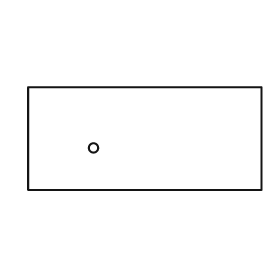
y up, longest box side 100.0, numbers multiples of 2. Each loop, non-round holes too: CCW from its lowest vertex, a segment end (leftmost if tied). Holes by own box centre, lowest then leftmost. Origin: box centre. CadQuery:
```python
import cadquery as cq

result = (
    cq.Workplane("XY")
    .moveTo(-50.0, -22.0)
    .lineTo(50.0, -22.0)
    .lineTo(50.0, 22.0)
    .lineTo(-50.0, 22.0)
    .close()
    .moveTo(-22.0, -4.0)
    .circle(2.0)
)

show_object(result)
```